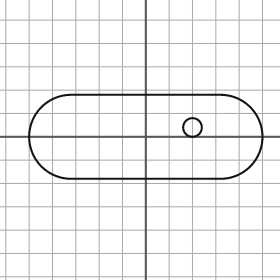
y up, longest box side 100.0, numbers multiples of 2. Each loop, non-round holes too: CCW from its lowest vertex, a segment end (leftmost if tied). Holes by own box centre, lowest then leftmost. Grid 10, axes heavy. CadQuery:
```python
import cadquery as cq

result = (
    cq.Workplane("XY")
    .moveTo(-32.0, -18.0)
    .lineTo(32.0, -18.0)
    .threePointArc((50.0, 0.0), (32.0, 18.0))
    .lineTo(-32.0, 18.0)
    .threePointArc((-50.0, 0.0), (-32.0, -18.0))
    .close()
    .moveTo(20.0, 4.0)
    .circle(4.0)
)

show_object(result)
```